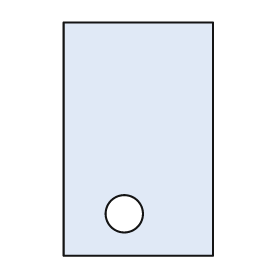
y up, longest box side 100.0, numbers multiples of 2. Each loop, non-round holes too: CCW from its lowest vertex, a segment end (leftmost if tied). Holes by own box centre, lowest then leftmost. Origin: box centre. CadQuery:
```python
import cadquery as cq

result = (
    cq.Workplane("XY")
    .moveTo(-32.0, -50.0)
    .lineTo(32.0, -50.0)
    .lineTo(32.0, 50.0)
    .lineTo(-32.0, 50.0)
    .close()
    .moveTo(-6.0, -32.0)
    .circle(8.0)
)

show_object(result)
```